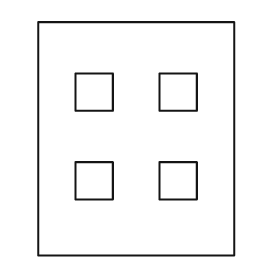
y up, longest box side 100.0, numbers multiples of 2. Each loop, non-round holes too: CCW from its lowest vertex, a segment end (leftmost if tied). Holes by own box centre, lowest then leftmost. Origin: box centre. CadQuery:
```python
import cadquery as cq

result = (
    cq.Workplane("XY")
    .moveTo(-42.0, -50.0)
    .lineTo(42.0, -50.0)
    .lineTo(42.0, 50.0)
    .lineTo(-42.0, 50.0)
    .close()
    .moveTo(-26.0, -26.0)
    .lineTo(-10.0, -26.0)
    .lineTo(-10.0, -10.0)
    .lineTo(-26.0, -10.0)
    .close()
    .moveTo(10.0, -26.0)
    .lineTo(26.0, -26.0)
    .lineTo(26.0, -10.0)
    .lineTo(10.0, -10.0)
    .close()
    .moveTo(-26.0, 12.0)
    .lineTo(-10.0, 12.0)
    .lineTo(-10.0, 28.0)
    .lineTo(-26.0, 28.0)
    .close()
    .moveTo(10.0, 12.0)
    .lineTo(26.0, 12.0)
    .lineTo(26.0, 28.0)
    .lineTo(10.0, 28.0)
    .close()
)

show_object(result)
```